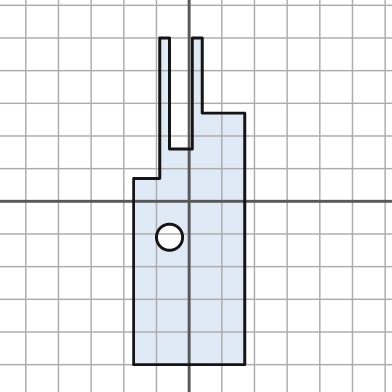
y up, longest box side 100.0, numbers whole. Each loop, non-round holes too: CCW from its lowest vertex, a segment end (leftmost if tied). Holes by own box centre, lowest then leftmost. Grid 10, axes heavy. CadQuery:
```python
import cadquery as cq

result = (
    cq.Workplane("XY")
    .moveTo(-17.0, -50.0)
    .lineTo(17.0, -50.0)
    .lineTo(17.0, 27.0)
    .lineTo(4.0, 27.0)
    .lineTo(4.0, 50.0)
    .lineTo(1.0, 50.0)
    .lineTo(1.0, 16.0)
    .lineTo(-6.0, 16.0)
    .lineTo(-6.0, 50.0)
    .lineTo(-9.0, 50.0)
    .lineTo(-9.0, 7.0)
    .lineTo(-17.0, 7.0)
    .close()
    .moveTo(-6.0, -11.0)
    .circle(4.0)
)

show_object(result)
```